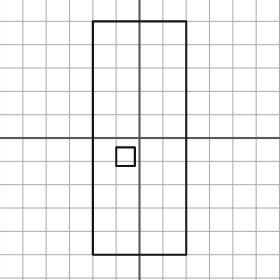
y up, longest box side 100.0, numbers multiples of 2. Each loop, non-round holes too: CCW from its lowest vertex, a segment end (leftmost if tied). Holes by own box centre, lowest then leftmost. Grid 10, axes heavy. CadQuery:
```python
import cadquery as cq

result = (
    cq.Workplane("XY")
    .moveTo(-20.0, -50.0)
    .lineTo(20.0, -50.0)
    .lineTo(20.0, 50.0)
    .lineTo(-20.0, 50.0)
    .close()
    .moveTo(-10.0, -12.0)
    .lineTo(-2.0, -12.0)
    .lineTo(-2.0, -4.0)
    .lineTo(-10.0, -4.0)
    .close()
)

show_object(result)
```